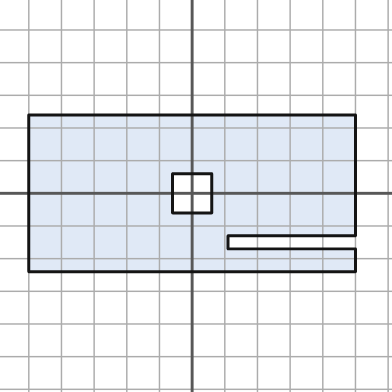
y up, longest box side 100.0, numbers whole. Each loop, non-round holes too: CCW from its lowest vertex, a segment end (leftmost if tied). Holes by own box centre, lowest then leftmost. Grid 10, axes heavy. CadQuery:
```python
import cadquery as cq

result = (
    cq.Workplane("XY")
    .moveTo(-50.0, -24.0)
    .lineTo(50.0, -24.0)
    .lineTo(50.0, -17.0)
    .lineTo(11.0, -17.0)
    .lineTo(11.0, -13.0)
    .lineTo(50.0, -13.0)
    .lineTo(50.0, 24.0)
    .lineTo(-50.0, 24.0)
    .close()
    .moveTo(-6.0, -6.0)
    .lineTo(6.0, -6.0)
    .lineTo(6.0, 6.0)
    .lineTo(-6.0, 6.0)
    .close()
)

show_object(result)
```